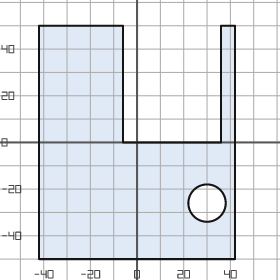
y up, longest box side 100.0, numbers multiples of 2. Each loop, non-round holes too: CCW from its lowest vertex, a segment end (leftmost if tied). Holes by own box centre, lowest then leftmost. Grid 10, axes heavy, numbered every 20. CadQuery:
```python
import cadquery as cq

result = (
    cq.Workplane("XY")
    .moveTo(-42.0, -50.0)
    .lineTo(42.0, -50.0)
    .lineTo(42.0, 50.0)
    .lineTo(36.0, 50.0)
    .lineTo(36.0, 0.0)
    .lineTo(-6.0, 0.0)
    .lineTo(-6.0, 50.0)
    .lineTo(-42.0, 50.0)
    .close()
    .moveTo(30.0, -26.0)
    .circle(8.0)
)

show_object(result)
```